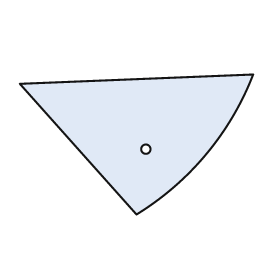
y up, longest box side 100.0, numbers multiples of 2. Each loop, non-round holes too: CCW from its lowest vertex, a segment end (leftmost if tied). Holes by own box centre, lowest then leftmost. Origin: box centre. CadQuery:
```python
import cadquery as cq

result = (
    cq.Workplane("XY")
    .moveTo(0.0, -30.0)
    .threePointArc((30.0, -4.0), (50.0, 30.0))
    .lineTo(-50.0, 26.0)
    .close()
    .moveTo(4.0, -2.0)
    .circle(2.0)
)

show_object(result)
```